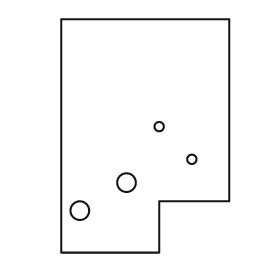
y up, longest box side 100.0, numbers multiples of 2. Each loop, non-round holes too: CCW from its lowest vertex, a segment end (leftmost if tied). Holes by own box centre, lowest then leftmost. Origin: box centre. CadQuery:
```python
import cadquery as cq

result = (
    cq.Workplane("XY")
    .moveTo(-36.0, -50.0)
    .lineTo(6.0, -50.0)
    .lineTo(6.0, -28.0)
    .lineTo(36.0, -28.0)
    .lineTo(36.0, 50.0)
    .lineTo(-36.0, 50.0)
    .close()
    .moveTo(-28.0, -32.0)
    .circle(4.0)
    .moveTo(-8.0, -20.0)
    .circle(4.0)
    .moveTo(20.0, -10.0)
    .circle(2.0)
    .moveTo(6.0, 4.0)
    .circle(2.0)
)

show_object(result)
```